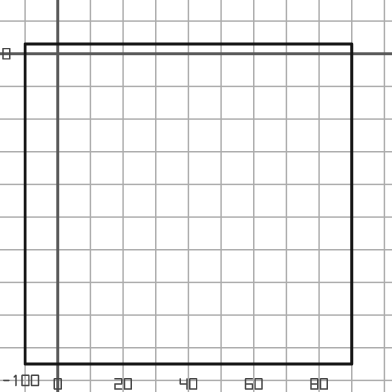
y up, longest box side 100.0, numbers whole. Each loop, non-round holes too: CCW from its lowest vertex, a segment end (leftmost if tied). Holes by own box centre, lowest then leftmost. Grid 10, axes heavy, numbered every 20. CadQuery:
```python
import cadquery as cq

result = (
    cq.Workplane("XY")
    .moveTo(-10.0, -95.0)
    .lineTo(90.0, -95.0)
    .lineTo(90.0, 3.0)
    .lineTo(-10.0, 3.0)
    .close()
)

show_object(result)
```